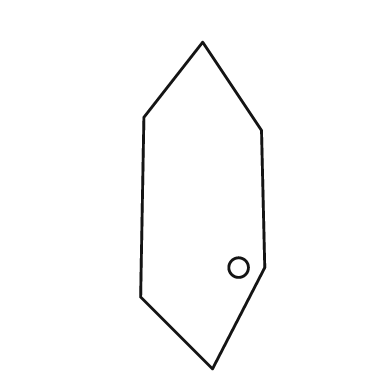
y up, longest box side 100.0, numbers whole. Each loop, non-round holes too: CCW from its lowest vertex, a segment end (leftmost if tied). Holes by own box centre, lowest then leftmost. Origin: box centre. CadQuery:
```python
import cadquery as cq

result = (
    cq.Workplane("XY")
    .moveTo(3.0, -50.0)
    .lineTo(19.0, -19.0)
    .lineTo(18.0, 23.0)
    .lineTo(0.0, 50.0)
    .lineTo(-18.0, 27.0)
    .lineTo(-19.0, -28.0)
    .close()
    .moveTo(11.0, -19.0)
    .circle(3.0)
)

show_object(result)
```